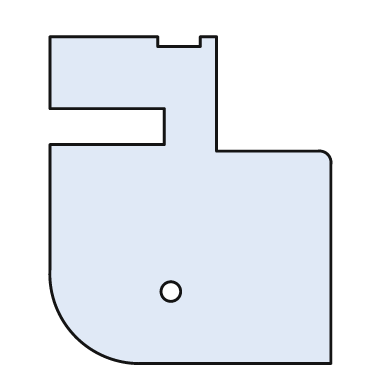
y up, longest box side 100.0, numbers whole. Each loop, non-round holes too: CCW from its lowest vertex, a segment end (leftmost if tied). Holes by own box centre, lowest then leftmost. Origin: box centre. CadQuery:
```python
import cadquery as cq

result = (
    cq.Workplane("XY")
    .moveTo(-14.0, -50.0)
    .lineTo(43.0, -50.0)
    .lineTo(43.0, 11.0)
    .threePointArc((42.0, 14.0), (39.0, 15.0))
    .lineTo(8.0, 15.0)
    .lineTo(8.0, 50.0)
    .lineTo(3.0, 50.0)
    .lineTo(3.0, 47.0)
    .lineTo(-10.0, 47.0)
    .lineTo(-10.0, 50.0)
    .lineTo(-43.0, 50.0)
    .lineTo(-43.0, 28.0)
    .lineTo(-8.0, 28.0)
    .lineTo(-8.0, 17.0)
    .lineTo(-43.0, 17.0)
    .lineTo(-43.0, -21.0)
    .threePointArc((-35.0, -42.0), (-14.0, -50.0))
    .close()
    .moveTo(-6.0, -28.0)
    .circle(3.0)
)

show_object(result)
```